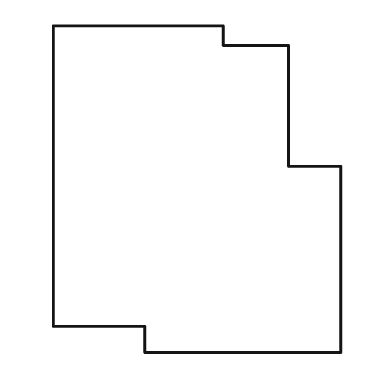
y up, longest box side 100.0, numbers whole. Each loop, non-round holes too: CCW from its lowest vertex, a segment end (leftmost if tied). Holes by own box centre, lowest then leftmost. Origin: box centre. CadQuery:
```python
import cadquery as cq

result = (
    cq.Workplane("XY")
    .moveTo(-16.0, -50.0)
    .lineTo(44.0, -50.0)
    .lineTo(44.0, 7.0)
    .lineTo(28.0, 7.0)
    .lineTo(28.0, 44.0)
    .lineTo(8.0, 44.0)
    .lineTo(8.0, 50.0)
    .lineTo(-44.0, 50.0)
    .lineTo(-44.0, -42.0)
    .lineTo(-16.0, -42.0)
    .close()
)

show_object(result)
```